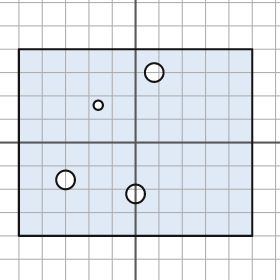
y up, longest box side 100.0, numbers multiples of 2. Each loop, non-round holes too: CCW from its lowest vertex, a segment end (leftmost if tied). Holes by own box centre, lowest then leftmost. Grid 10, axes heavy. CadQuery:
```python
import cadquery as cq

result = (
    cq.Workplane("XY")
    .moveTo(-50.0, -40.0)
    .lineTo(50.0, -40.0)
    .lineTo(50.0, 40.0)
    .lineTo(-50.0, 40.0)
    .close()
    .moveTo(0.0, -22.0)
    .circle(4.0)
    .moveTo(-30.0, -16.0)
    .circle(4.0)
    .moveTo(-16.0, 16.0)
    .circle(2.0)
    .moveTo(8.0, 30.0)
    .circle(4.0)
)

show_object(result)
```